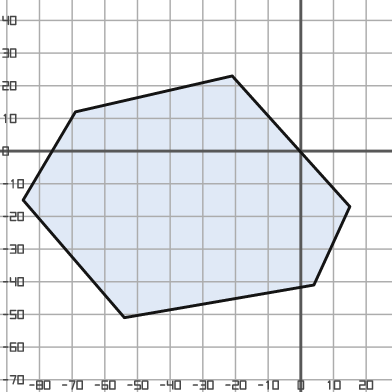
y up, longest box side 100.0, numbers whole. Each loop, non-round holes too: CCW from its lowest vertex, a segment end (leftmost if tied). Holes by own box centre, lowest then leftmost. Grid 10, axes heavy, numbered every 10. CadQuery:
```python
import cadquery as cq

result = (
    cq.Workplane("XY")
    .moveTo(-54.0, -51.0)
    .lineTo(4.0, -41.0)
    .lineTo(15.0, -17.0)
    .lineTo(-21.0, 23.0)
    .lineTo(-69.0, 12.0)
    .lineTo(-85.0, -15.0)
    .close()
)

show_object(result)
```